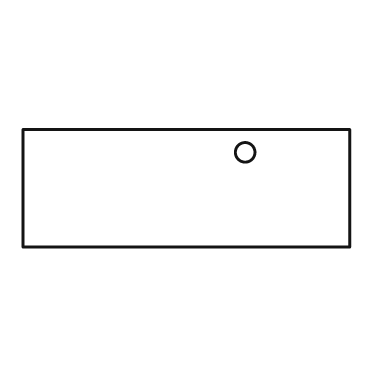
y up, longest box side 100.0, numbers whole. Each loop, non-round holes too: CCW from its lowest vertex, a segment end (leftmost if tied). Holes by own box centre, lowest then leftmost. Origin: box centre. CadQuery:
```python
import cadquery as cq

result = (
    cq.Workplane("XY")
    .moveTo(-50.0, -18.0)
    .lineTo(50.0, -18.0)
    .lineTo(50.0, 18.0)
    .lineTo(-50.0, 18.0)
    .close()
    .moveTo(18.0, 11.0)
    .circle(3.0)
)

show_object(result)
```